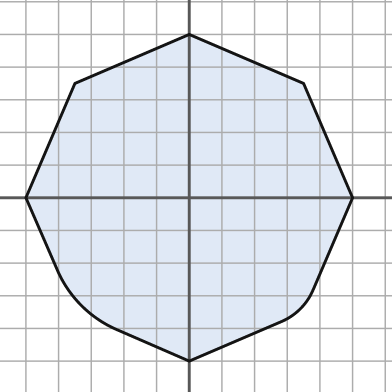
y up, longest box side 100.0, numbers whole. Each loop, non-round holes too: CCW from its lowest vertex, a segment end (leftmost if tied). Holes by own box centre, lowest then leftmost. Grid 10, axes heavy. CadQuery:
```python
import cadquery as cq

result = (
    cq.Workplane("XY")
    .moveTo(0.0, -50.0)
    .lineTo(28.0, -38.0)
    .threePointArc((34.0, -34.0), (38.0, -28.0))
    .lineTo(50.0, 0.0)
    .lineTo(35.0, 35.0)
    .lineTo(0.0, 50.0)
    .lineTo(-35.0, 35.0)
    .lineTo(-50.0, 0.0)
    .lineTo(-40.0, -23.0)
    .threePointArc((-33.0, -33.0), (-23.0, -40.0))
    .close()
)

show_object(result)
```